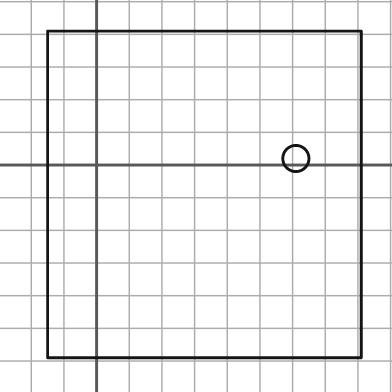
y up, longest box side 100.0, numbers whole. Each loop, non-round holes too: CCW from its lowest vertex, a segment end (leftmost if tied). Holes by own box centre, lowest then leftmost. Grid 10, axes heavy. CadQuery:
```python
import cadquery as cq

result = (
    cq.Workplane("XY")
    .moveTo(-15.0, -59.0)
    .lineTo(81.0, -59.0)
    .lineTo(81.0, 41.0)
    .lineTo(-15.0, 41.0)
    .close()
    .moveTo(61.0, 2.0)
    .circle(4.0)
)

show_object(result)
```